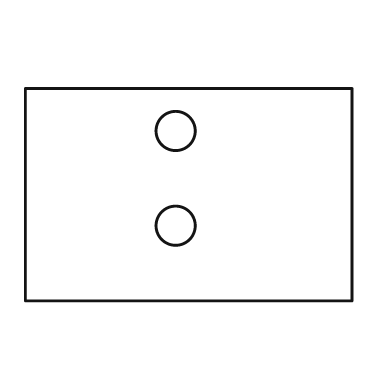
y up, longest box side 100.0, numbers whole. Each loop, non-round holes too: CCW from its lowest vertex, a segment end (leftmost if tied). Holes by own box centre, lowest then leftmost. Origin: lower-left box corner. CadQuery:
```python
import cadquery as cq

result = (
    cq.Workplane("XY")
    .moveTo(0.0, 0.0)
    .lineTo(100.0, 0.0)
    .lineTo(100.0, 65.0)
    .lineTo(0.0, 65.0)
    .close()
    .moveTo(46.0, 23.0)
    .circle(6.0)
    .moveTo(46.0, 52.0)
    .circle(6.0)
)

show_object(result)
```